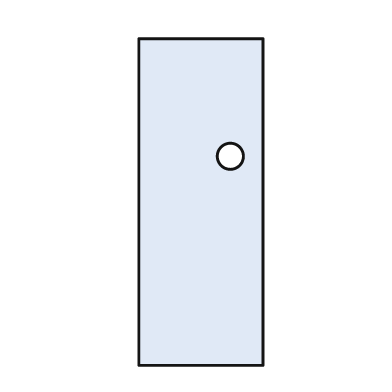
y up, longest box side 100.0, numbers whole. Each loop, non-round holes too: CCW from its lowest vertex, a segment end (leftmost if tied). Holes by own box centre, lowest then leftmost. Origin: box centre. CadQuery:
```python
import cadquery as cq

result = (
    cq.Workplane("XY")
    .moveTo(-19.0, -50.0)
    .lineTo(19.0, -50.0)
    .lineTo(19.0, 50.0)
    .lineTo(-19.0, 50.0)
    .close()
    .moveTo(9.0, 14.0)
    .circle(4.0)
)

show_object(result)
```